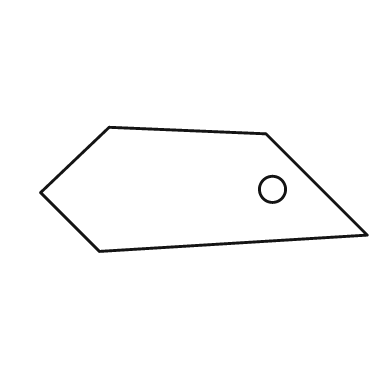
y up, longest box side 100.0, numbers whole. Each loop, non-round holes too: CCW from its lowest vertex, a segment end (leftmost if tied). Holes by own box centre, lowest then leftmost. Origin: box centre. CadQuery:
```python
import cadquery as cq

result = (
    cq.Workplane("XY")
    .moveTo(-32.0, -19.0)
    .lineTo(50.0, -14.0)
    .lineTo(19.0, 17.0)
    .lineTo(-29.0, 19.0)
    .lineTo(-50.0, -1.0)
    .close()
    .moveTo(21.0, 0.0)
    .circle(4.0)
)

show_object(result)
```